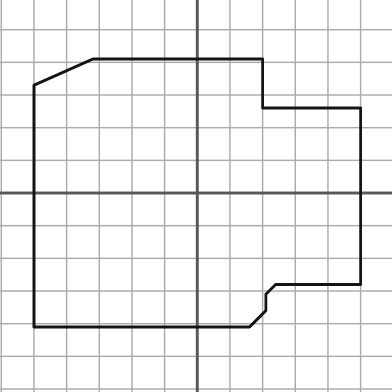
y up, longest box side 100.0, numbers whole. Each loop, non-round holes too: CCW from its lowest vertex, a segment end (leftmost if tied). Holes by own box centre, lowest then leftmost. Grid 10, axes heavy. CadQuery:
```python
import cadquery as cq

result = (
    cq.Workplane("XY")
    .moveTo(-50.0, -41.0)
    .lineTo(16.0, -41.0)
    .lineTo(21.0, -36.0)
    .lineTo(21.0, -31.0)
    .lineTo(24.0, -28.0)
    .lineTo(50.0, -28.0)
    .lineTo(50.0, 26.0)
    .lineTo(20.0, 26.0)
    .lineTo(20.0, 41.0)
    .lineTo(-32.0, 41.0)
    .lineTo(-50.0, 33.0)
    .close()
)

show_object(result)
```